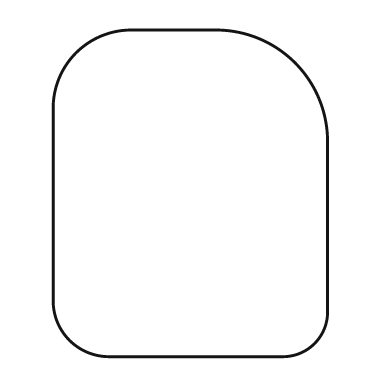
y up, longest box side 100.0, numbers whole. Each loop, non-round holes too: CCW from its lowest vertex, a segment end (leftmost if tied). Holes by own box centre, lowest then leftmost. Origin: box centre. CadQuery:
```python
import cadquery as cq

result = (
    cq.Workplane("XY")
    .moveTo(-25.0, -50.0)
    .lineTo(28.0, -50.0)
    .threePointArc((38.0, -46.0), (42.0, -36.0))
    .lineTo(42.0, 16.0)
    .threePointArc((32.0, 40.0), (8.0, 50.0))
    .lineTo(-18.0, 50.0)
    .threePointArc((-35.0, 43.0), (-42.0, 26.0))
    .lineTo(-42.0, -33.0)
    .threePointArc((-37.0, -45.0), (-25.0, -50.0))
    .close()
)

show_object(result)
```